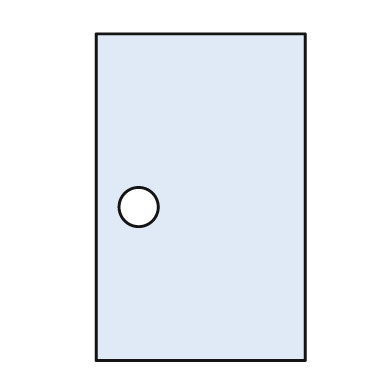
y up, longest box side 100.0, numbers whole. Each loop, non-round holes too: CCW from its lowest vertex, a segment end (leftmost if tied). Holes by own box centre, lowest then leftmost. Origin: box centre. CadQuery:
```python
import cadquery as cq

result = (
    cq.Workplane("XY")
    .moveTo(-32.0, -50.0)
    .lineTo(32.0, -50.0)
    .lineTo(32.0, 50.0)
    .lineTo(-32.0, 50.0)
    .close()
    .moveTo(-19.0, -3.0)
    .circle(6.0)
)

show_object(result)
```